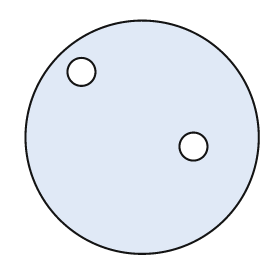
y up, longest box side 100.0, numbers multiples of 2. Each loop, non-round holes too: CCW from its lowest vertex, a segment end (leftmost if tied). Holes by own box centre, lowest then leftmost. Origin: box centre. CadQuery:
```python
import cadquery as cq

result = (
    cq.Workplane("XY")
    .moveTo(0.0, 0.0)
    .circle(50.0)
    .moveTo(22.0, -4.0)
    .circle(6.0)
    .moveTo(-26.0, 28.0)
    .circle(6.0)
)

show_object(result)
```